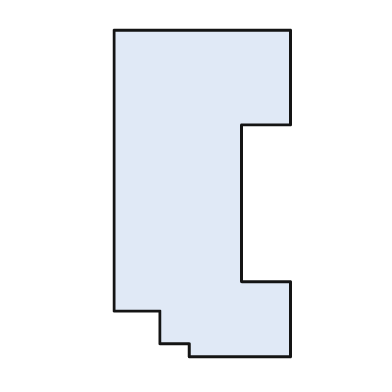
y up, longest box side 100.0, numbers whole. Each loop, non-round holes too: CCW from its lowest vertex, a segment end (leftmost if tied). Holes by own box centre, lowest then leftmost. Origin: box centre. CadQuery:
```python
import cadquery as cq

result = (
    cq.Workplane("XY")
    .moveTo(-4.0, -50.0)
    .lineTo(27.0, -50.0)
    .lineTo(27.0, -27.0)
    .lineTo(12.0, -27.0)
    .lineTo(12.0, 21.0)
    .lineTo(27.0, 21.0)
    .lineTo(27.0, 50.0)
    .lineTo(-27.0, 50.0)
    .lineTo(-27.0, -36.0)
    .lineTo(-13.0, -36.0)
    .lineTo(-13.0, -46.0)
    .lineTo(-4.0, -46.0)
    .close()
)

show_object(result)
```